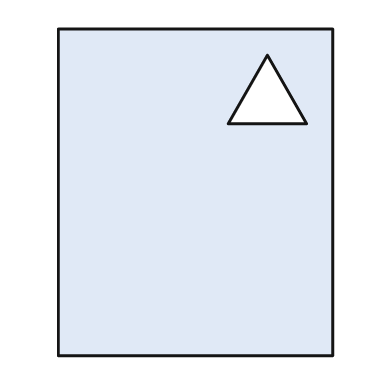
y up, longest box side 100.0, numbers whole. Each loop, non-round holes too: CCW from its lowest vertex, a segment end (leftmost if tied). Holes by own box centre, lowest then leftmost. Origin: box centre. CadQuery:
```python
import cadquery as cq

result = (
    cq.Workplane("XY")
    .moveTo(-42.0, -50.0)
    .lineTo(42.0, -50.0)
    .lineTo(42.0, 50.0)
    .lineTo(-42.0, 50.0)
    .close()
    .moveTo(10.0, 21.0)
    .lineTo(34.0, 21.0)
    .lineTo(22.0, 42.0)
    .close()
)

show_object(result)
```